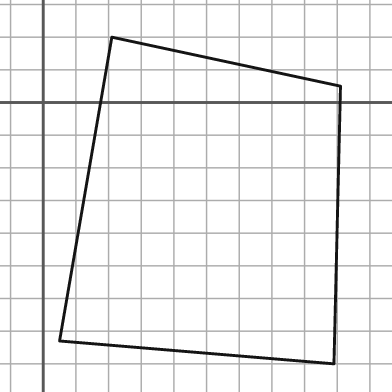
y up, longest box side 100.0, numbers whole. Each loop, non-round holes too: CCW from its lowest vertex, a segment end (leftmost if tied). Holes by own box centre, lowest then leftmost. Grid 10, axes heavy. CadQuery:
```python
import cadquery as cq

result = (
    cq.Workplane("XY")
    .moveTo(89.0, -80.0)
    .lineTo(91.0, 5.0)
    .lineTo(21.0, 20.0)
    .lineTo(5.0, -73.0)
    .close()
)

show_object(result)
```